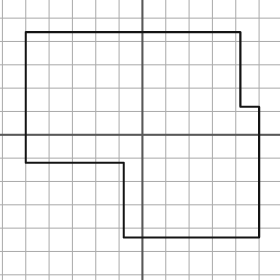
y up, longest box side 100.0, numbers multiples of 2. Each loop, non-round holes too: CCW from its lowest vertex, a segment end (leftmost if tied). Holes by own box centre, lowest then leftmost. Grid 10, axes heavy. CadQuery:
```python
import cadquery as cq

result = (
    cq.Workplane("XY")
    .moveTo(-8.0, -44.0)
    .lineTo(50.0, -44.0)
    .lineTo(50.0, 12.0)
    .lineTo(42.0, 12.0)
    .lineTo(42.0, 44.0)
    .lineTo(-50.0, 44.0)
    .lineTo(-50.0, -12.0)
    .lineTo(-8.0, -12.0)
    .close()
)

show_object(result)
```